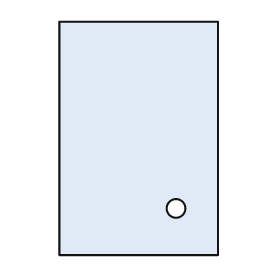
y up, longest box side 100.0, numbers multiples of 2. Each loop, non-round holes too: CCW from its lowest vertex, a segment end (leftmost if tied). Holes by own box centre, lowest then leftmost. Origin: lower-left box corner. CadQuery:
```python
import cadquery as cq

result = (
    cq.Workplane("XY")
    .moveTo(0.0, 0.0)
    .lineTo(68.0, 0.0)
    .lineTo(68.0, 100.0)
    .lineTo(0.0, 100.0)
    .close()
    .moveTo(50.0, 20.0)
    .circle(4.0)
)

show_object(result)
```